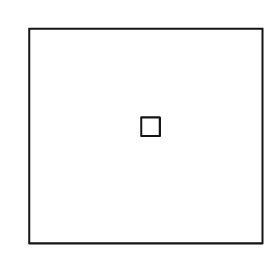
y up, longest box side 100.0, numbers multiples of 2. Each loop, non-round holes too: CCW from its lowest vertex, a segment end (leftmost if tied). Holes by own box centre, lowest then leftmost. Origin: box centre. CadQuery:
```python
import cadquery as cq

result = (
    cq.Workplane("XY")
    .moveTo(-50.0, -46.0)
    .lineTo(50.0, -46.0)
    .lineTo(50.0, 46.0)
    .lineTo(-50.0, 46.0)
    .close()
    .moveTo(-2.0, 0.0)
    .lineTo(6.0, 0.0)
    .lineTo(6.0, 8.0)
    .lineTo(-2.0, 8.0)
    .close()
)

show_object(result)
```